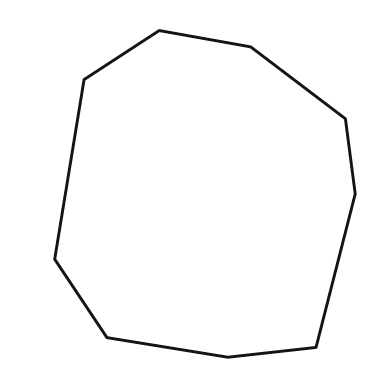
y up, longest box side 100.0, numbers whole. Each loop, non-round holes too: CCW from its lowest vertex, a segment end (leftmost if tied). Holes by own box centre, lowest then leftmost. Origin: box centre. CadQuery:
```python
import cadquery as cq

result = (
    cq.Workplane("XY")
    .moveTo(7.0, -50.0)
    .lineTo(34.0, -47.0)
    .lineTo(46.0, 0.0)
    .lineTo(43.0, 23.0)
    .lineTo(14.0, 45.0)
    .lineTo(-14.0, 50.0)
    .lineTo(-37.0, 35.0)
    .lineTo(-46.0, -20.0)
    .lineTo(-30.0, -44.0)
    .close()
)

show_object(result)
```